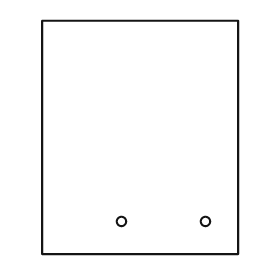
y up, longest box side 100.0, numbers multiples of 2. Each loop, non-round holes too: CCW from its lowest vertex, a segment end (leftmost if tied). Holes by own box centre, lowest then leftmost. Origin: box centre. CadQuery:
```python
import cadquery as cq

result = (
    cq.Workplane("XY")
    .moveTo(-42.0, -50.0)
    .lineTo(42.0, -50.0)
    .lineTo(42.0, 50.0)
    .lineTo(-42.0, 50.0)
    .close()
    .moveTo(-8.0, -36.0)
    .circle(2.0)
    .moveTo(28.0, -36.0)
    .circle(2.0)
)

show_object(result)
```